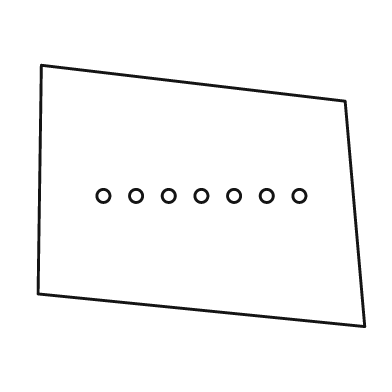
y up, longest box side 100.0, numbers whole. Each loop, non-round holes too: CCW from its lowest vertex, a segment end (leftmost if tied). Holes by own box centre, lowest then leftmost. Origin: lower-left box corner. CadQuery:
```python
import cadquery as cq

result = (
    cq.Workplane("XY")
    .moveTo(100.0, 0.0)
    .lineTo(94.0, 69.0)
    .lineTo(1.0, 80.0)
    .lineTo(0.0, 10.0)
    .close()
    .moveTo(20.0, 40.0)
    .circle(2.0)
    .moveTo(30.0, 40.0)
    .circle(2.0)
    .moveTo(40.0, 40.0)
    .circle(2.0)
    .moveTo(50.0, 40.0)
    .circle(2.0)
    .moveTo(60.0, 40.0)
    .circle(2.0)
    .moveTo(70.0, 40.0)
    .circle(2.0)
    .moveTo(80.0, 40.0)
    .circle(2.0)
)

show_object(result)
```